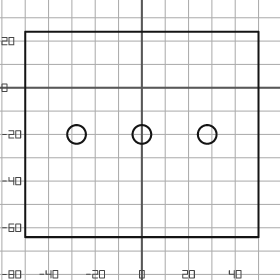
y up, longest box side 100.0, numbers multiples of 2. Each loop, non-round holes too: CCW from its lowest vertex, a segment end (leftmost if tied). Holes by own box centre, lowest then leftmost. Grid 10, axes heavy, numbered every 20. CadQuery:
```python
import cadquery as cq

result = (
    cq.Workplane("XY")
    .moveTo(-50.0, -64.0)
    .lineTo(50.0, -64.0)
    .lineTo(50.0, 24.0)
    .lineTo(-50.0, 24.0)
    .close()
    .moveTo(-28.0, -20.0)
    .circle(4.0)
    .moveTo(0.0, -20.0)
    .circle(4.0)
    .moveTo(28.0, -20.0)
    .circle(4.0)
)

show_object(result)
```